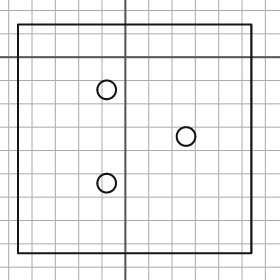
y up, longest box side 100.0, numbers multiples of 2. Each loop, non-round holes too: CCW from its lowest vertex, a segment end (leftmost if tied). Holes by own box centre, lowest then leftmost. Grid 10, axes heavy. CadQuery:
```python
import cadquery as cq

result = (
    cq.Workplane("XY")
    .moveTo(-46.0, -84.0)
    .lineTo(54.0, -84.0)
    .lineTo(54.0, 14.0)
    .lineTo(-46.0, 14.0)
    .close()
    .moveTo(-8.0, -54.0)
    .circle(4.0)
    .moveTo(26.0, -34.0)
    .circle(4.0)
    .moveTo(-8.0, -14.0)
    .circle(4.0)
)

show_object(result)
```